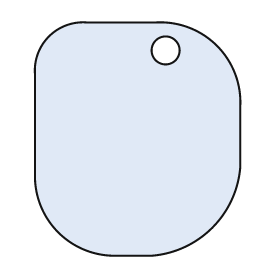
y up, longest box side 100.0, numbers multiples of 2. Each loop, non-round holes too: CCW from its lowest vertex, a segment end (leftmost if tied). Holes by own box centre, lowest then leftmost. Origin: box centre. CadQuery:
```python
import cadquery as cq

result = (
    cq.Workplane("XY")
    .moveTo(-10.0, -50.0)
    .lineTo(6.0, -50.0)
    .threePointArc((32.0, -38.0), (44.0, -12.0))
    .lineTo(44.0, 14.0)
    .threePointArc((34.0, 40.0), (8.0, 50.0))
    .lineTo(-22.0, 50.0)
    .threePointArc((-38.0, 44.0), (-44.0, 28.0))
    .lineTo(-44.0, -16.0)
    .threePointArc((-34.0, -40.0), (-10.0, -50.0))
    .close()
    .moveTo(12.0, 38.0)
    .circle(6.0)
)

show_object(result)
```